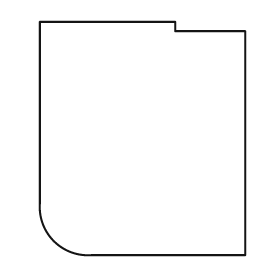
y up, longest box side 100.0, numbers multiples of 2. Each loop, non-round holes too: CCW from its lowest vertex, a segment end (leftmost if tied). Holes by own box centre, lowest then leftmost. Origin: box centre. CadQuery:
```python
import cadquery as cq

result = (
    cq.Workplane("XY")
    .moveTo(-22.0, -50.0)
    .lineTo(44.0, -50.0)
    .lineTo(44.0, 46.0)
    .lineTo(14.0, 46.0)
    .lineTo(14.0, 50.0)
    .lineTo(-44.0, 50.0)
    .lineTo(-44.0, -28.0)
    .threePointArc((-38.0, -44.0), (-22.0, -50.0))
    .close()
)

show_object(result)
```